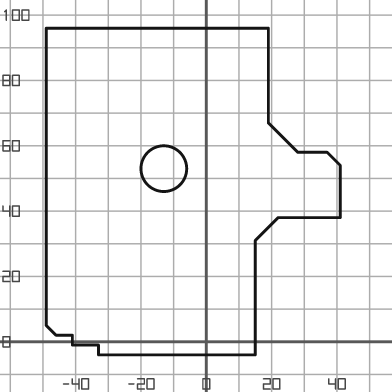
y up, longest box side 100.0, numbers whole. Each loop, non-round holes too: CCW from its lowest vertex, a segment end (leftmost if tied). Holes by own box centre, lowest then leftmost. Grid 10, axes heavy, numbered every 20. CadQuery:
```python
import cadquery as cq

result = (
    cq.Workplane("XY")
    .moveTo(-33.0, -4.0)
    .lineTo(15.0, -4.0)
    .lineTo(15.0, 31.0)
    .lineTo(22.0, 38.0)
    .lineTo(41.0, 38.0)
    .lineTo(41.0, 54.0)
    .lineTo(37.0, 58.0)
    .lineTo(28.0, 58.0)
    .lineTo(19.0, 67.0)
    .lineTo(19.0, 96.0)
    .lineTo(-49.0, 96.0)
    .lineTo(-49.0, 5.0)
    .lineTo(-46.0, 2.0)
    .lineTo(-41.0, 2.0)
    .lineTo(-41.0, -1.0)
    .lineTo(-33.0, -1.0)
    .close()
    .moveTo(-13.0, 53.0)
    .circle(7.0)
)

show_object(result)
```